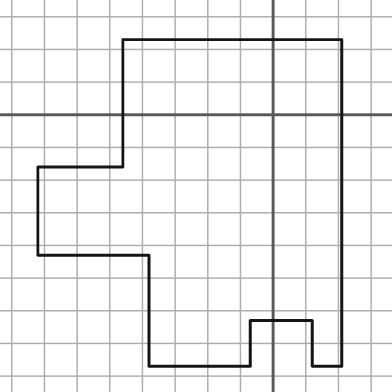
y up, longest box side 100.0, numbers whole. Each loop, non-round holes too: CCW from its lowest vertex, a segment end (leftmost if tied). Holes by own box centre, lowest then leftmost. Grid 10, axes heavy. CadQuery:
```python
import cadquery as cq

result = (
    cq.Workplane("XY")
    .moveTo(-38.0, -77.0)
    .lineTo(-7.0, -77.0)
    .lineTo(-7.0, -63.0)
    .lineTo(12.0, -63.0)
    .lineTo(12.0, -77.0)
    .lineTo(21.0, -77.0)
    .lineTo(21.0, 23.0)
    .lineTo(-46.0, 23.0)
    .lineTo(-46.0, -16.0)
    .lineTo(-72.0, -16.0)
    .lineTo(-72.0, -43.0)
    .lineTo(-38.0, -43.0)
    .close()
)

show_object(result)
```